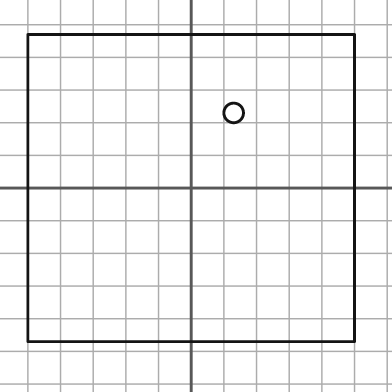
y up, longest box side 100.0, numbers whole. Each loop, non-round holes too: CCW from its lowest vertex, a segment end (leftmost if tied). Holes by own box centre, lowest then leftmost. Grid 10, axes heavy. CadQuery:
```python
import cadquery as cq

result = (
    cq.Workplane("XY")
    .moveTo(-50.0, -47.0)
    .lineTo(50.0, -47.0)
    .lineTo(50.0, 47.0)
    .lineTo(-50.0, 47.0)
    .close()
    .moveTo(13.0, 23.0)
    .circle(3.0)
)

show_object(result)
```